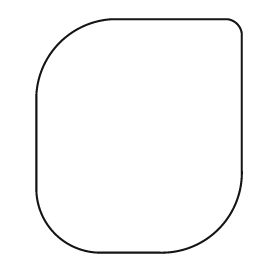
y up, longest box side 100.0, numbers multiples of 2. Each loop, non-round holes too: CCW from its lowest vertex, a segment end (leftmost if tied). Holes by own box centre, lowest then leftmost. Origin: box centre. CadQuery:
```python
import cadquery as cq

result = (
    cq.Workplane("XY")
    .moveTo(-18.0, -50.0)
    .lineTo(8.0, -50.0)
    .threePointArc((34.0, -40.0), (44.0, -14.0))
    .lineTo(44.0, 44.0)
    .threePointArc((42.0, 48.0), (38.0, 50.0))
    .lineTo(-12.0, 50.0)
    .threePointArc((-34.0, 40.0), (-44.0, 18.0))
    .lineTo(-44.0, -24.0)
    .threePointArc((-36.0, -42.0), (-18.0, -50.0))
    .close()
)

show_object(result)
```